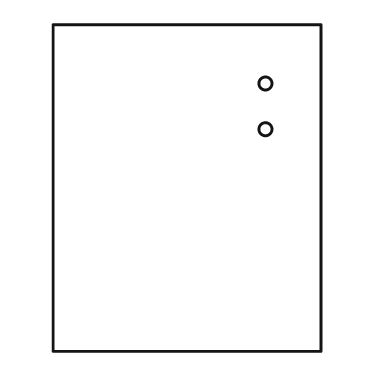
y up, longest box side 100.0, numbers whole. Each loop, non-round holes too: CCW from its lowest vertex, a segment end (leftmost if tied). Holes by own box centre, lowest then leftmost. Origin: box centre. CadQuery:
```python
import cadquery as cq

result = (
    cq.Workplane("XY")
    .moveTo(-41.0, -50.0)
    .lineTo(41.0, -50.0)
    .lineTo(41.0, 50.0)
    .lineTo(-41.0, 50.0)
    .close()
    .moveTo(24.0, 18.0)
    .circle(2.0)
    .moveTo(24.0, 32.0)
    .circle(2.0)
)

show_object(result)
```